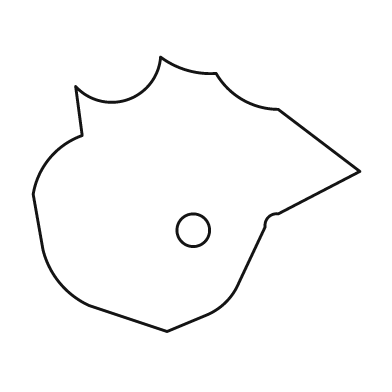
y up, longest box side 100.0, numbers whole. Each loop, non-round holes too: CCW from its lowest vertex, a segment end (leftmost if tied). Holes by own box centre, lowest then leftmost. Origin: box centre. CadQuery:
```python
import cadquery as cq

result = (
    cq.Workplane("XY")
    .moveTo(-9.0, -42.0)
    .lineTo(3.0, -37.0)
    .threePointArc((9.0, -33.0), (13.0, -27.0))
    .lineTo(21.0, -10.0)
    .threePointArc((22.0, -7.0), (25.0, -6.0))
    .lineTo(50.0, 7.0)
    .lineTo(25.0, 26.0)
    .threePointArc((14.0, 29.0), (6.0, 37.0))
    .threePointArc((-3.0, 38.0), (-11.0, 42.0))
    .threePointArc((-21.0, 29.0), (-37.0, 33.0))
    .lineTo(-35.0, 18.0)
    .threePointArc((-45.0, 11.0), (-50.0, 0.0))
    .lineTo(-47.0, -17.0)
    .threePointArc((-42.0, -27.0), (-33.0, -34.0))
    .close()
    .moveTo(-1.0, -11.0)
    .circle(5.0)
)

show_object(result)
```